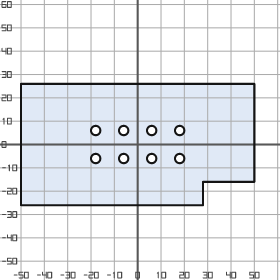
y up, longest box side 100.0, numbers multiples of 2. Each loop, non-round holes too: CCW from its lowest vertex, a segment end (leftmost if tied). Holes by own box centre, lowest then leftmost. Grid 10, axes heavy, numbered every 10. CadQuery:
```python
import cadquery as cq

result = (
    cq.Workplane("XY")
    .moveTo(-50.0, -26.0)
    .lineTo(28.0, -26.0)
    .lineTo(28.0, -16.0)
    .lineTo(50.0, -16.0)
    .lineTo(50.0, 26.0)
    .lineTo(-50.0, 26.0)
    .close()
    .moveTo(-18.0, -6.0)
    .circle(2.0)
    .moveTo(-6.0, -6.0)
    .circle(2.0)
    .moveTo(6.0, -6.0)
    .circle(2.0)
    .moveTo(18.0, -6.0)
    .circle(2.0)
    .moveTo(-18.0, 6.0)
    .circle(2.0)
    .moveTo(-6.0, 6.0)
    .circle(2.0)
    .moveTo(6.0, 6.0)
    .circle(2.0)
    .moveTo(18.0, 6.0)
    .circle(2.0)
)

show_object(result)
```